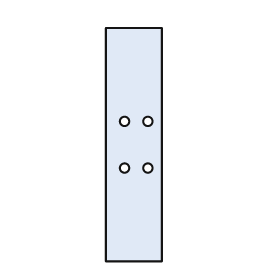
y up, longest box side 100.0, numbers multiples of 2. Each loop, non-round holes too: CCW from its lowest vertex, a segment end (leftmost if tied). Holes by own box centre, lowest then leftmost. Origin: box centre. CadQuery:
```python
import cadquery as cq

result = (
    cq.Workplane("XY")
    .moveTo(-12.0, -50.0)
    .lineTo(12.0, -50.0)
    .lineTo(12.0, 50.0)
    .lineTo(-12.0, 50.0)
    .close()
    .moveTo(-4.0, -10.0)
    .circle(2.0)
    .moveTo(6.0, -10.0)
    .circle(2.0)
    .moveTo(-4.0, 10.0)
    .circle(2.0)
    .moveTo(6.0, 10.0)
    .circle(2.0)
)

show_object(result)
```